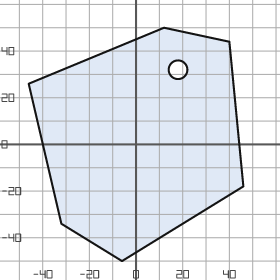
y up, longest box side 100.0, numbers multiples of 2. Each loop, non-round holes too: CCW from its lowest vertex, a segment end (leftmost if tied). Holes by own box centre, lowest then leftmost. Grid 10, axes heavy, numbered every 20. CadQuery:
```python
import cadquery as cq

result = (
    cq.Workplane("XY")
    .moveTo(-6.0, -50.0)
    .lineTo(46.0, -18.0)
    .lineTo(40.0, 44.0)
    .lineTo(12.0, 50.0)
    .lineTo(-46.0, 26.0)
    .lineTo(-32.0, -34.0)
    .close()
    .moveTo(18.0, 32.0)
    .circle(4.0)
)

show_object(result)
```